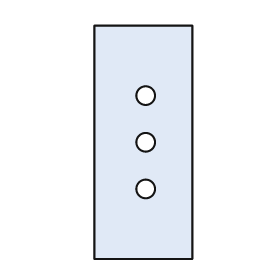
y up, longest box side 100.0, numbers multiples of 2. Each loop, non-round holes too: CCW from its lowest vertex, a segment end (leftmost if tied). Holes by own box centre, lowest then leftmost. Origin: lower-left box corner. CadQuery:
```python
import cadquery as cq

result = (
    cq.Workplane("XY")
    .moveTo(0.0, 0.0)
    .lineTo(42.0, 0.0)
    .lineTo(42.0, 100.0)
    .lineTo(0.0, 100.0)
    .close()
    .moveTo(22.0, 30.0)
    .circle(4.0)
    .moveTo(22.0, 50.0)
    .circle(4.0)
    .moveTo(22.0, 70.0)
    .circle(4.0)
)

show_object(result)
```